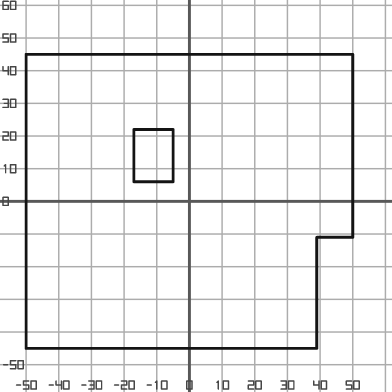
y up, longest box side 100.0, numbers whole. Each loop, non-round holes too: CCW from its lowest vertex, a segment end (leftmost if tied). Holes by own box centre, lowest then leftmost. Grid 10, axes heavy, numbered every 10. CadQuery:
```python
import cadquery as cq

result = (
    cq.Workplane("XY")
    .moveTo(-50.0, -45.0)
    .lineTo(39.0, -45.0)
    .lineTo(39.0, -11.0)
    .lineTo(50.0, -11.0)
    .lineTo(50.0, 45.0)
    .lineTo(-50.0, 45.0)
    .close()
    .moveTo(-17.0, 6.0)
    .lineTo(-5.0, 6.0)
    .lineTo(-5.0, 22.0)
    .lineTo(-17.0, 22.0)
    .close()
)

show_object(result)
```